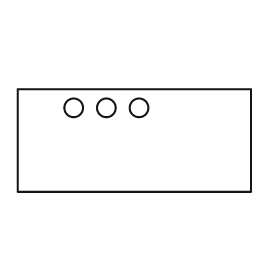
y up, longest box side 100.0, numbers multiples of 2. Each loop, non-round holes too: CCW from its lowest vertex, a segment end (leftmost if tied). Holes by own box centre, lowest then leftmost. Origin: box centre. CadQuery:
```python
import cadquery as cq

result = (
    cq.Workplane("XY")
    .moveTo(-50.0, -22.0)
    .lineTo(50.0, -22.0)
    .lineTo(50.0, 22.0)
    .lineTo(-50.0, 22.0)
    .close()
    .moveTo(-26.0, 14.0)
    .circle(4.0)
    .moveTo(-12.0, 14.0)
    .circle(4.0)
    .moveTo(2.0, 14.0)
    .circle(4.0)
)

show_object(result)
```